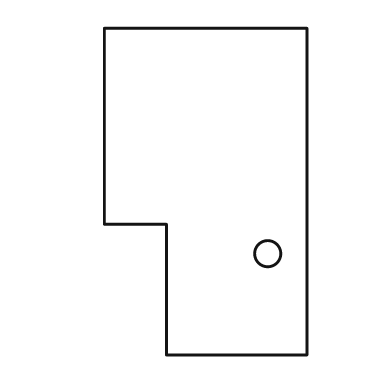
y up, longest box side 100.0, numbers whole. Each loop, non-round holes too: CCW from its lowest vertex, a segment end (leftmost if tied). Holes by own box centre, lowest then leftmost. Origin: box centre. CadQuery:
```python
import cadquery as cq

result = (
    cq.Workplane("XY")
    .moveTo(-12.0, -50.0)
    .lineTo(31.0, -50.0)
    .lineTo(31.0, 50.0)
    .lineTo(-31.0, 50.0)
    .lineTo(-31.0, -10.0)
    .lineTo(-12.0, -10.0)
    .close()
    .moveTo(19.0, -19.0)
    .circle(4.0)
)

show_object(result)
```